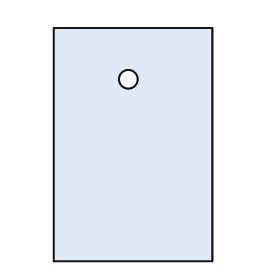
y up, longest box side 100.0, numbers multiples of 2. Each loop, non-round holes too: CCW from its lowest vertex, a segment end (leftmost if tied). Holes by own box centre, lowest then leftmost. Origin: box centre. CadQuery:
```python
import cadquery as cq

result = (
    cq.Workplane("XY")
    .moveTo(-34.0, -50.0)
    .lineTo(34.0, -50.0)
    .lineTo(34.0, 50.0)
    .lineTo(-34.0, 50.0)
    .close()
    .moveTo(-2.0, 28.0)
    .circle(4.0)
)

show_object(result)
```